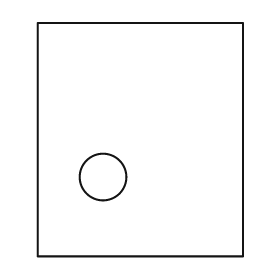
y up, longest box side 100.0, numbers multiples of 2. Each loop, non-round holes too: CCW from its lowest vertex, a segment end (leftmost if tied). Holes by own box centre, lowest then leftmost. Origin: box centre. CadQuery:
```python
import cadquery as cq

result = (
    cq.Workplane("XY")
    .moveTo(-44.0, -50.0)
    .lineTo(44.0, -50.0)
    .lineTo(44.0, 50.0)
    .lineTo(-44.0, 50.0)
    .close()
    .moveTo(-16.0, -16.0)
    .circle(10.0)
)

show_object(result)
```